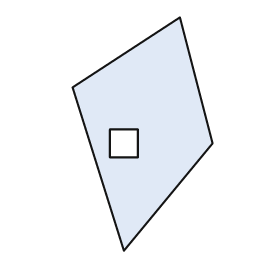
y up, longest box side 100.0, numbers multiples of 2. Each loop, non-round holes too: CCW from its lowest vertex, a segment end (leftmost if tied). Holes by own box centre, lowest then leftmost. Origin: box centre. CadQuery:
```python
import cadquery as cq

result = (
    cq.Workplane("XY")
    .moveTo(-8.0, -50.0)
    .lineTo(30.0, -4.0)
    .lineTo(16.0, 50.0)
    .lineTo(-30.0, 20.0)
    .close()
    .moveTo(-14.0, -10.0)
    .lineTo(-2.0, -10.0)
    .lineTo(-2.0, 2.0)
    .lineTo(-14.0, 2.0)
    .close()
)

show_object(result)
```